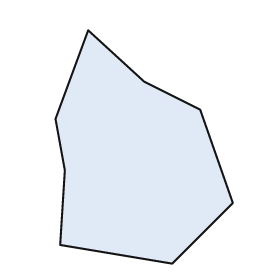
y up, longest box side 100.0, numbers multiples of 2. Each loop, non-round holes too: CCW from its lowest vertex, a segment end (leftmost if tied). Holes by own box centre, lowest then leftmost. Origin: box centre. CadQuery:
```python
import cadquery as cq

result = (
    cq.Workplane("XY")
    .moveTo(12.0, -50.0)
    .lineTo(38.0, -24.0)
    .lineTo(24.0, 16.0)
    .lineTo(0.0, 28.0)
    .lineTo(-24.0, 50.0)
    .lineTo(-38.0, 12.0)
    .lineTo(-34.0, -10.0)
    .lineTo(-36.0, -42.0)
    .close()
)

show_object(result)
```